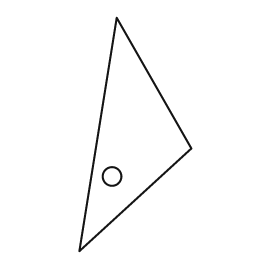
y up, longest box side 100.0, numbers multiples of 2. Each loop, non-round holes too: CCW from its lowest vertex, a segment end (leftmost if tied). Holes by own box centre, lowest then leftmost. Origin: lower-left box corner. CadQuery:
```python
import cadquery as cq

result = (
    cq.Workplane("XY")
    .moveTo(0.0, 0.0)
    .lineTo(48.0, 44.0)
    .lineTo(16.0, 100.0)
    .close()
    .moveTo(14.0, 32.0)
    .circle(4.0)
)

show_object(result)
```